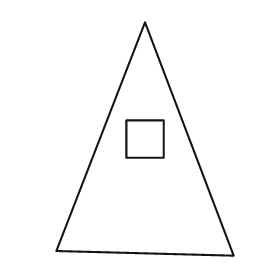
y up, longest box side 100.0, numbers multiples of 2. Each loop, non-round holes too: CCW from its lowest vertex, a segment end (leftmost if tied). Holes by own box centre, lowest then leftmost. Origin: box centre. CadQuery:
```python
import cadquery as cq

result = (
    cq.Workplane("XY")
    .moveTo(38.0, -50.0)
    .lineTo(0.0, 50.0)
    .lineTo(-38.0, -48.0)
    .close()
    .moveTo(-8.0, -8.0)
    .lineTo(8.0, -8.0)
    .lineTo(8.0, 8.0)
    .lineTo(-8.0, 8.0)
    .close()
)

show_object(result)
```